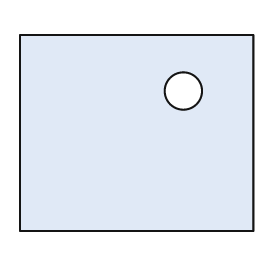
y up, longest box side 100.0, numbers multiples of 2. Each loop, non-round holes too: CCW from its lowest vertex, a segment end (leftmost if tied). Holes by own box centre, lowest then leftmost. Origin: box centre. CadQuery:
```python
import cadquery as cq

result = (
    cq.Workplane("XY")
    .moveTo(-50.0, -42.0)
    .lineTo(50.0, -42.0)
    .lineTo(50.0, 42.0)
    .lineTo(-50.0, 42.0)
    .close()
    .moveTo(20.0, 18.0)
    .circle(8.0)
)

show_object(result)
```